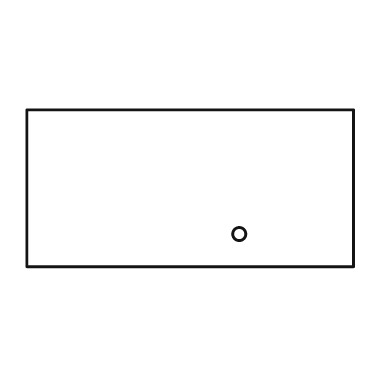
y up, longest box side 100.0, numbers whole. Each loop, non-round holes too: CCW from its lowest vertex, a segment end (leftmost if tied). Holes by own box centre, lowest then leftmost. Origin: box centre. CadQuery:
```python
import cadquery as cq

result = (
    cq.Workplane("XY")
    .moveTo(-50.0, -24.0)
    .lineTo(50.0, -24.0)
    .lineTo(50.0, 24.0)
    .lineTo(-50.0, 24.0)
    .close()
    .moveTo(15.0, -14.0)
    .circle(2.0)
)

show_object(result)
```